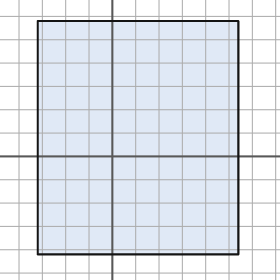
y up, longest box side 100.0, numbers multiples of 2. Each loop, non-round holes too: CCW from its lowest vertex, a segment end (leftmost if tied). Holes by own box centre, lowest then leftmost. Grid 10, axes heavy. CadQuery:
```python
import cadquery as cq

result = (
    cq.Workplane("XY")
    .moveTo(-32.0, -42.0)
    .lineTo(54.0, -42.0)
    .lineTo(54.0, 58.0)
    .lineTo(-32.0, 58.0)
    .close()
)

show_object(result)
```